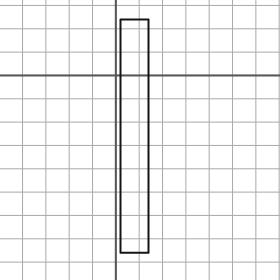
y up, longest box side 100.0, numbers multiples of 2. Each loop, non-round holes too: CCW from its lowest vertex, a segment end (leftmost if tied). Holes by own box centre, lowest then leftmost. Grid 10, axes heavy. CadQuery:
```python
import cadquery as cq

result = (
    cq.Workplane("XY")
    .moveTo(2.0, -76.0)
    .lineTo(14.0, -76.0)
    .lineTo(14.0, 24.0)
    .lineTo(2.0, 24.0)
    .close()
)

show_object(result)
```